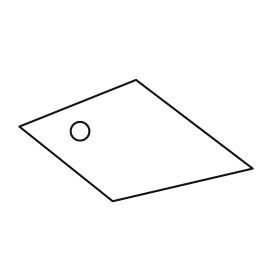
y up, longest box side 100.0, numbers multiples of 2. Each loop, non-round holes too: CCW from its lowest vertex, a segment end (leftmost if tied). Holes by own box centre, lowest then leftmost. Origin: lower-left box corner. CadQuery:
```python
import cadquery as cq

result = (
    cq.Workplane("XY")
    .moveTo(40.0, 0.0)
    .lineTo(100.0, 14.0)
    .lineTo(50.0, 52.0)
    .lineTo(0.0, 32.0)
    .close()
    .moveTo(26.0, 30.0)
    .circle(4.0)
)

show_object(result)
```